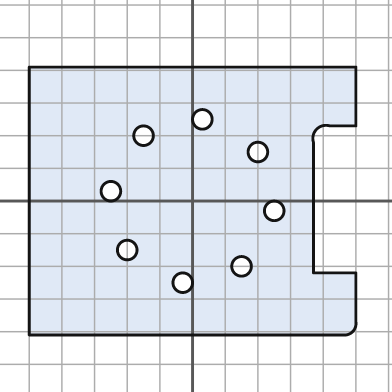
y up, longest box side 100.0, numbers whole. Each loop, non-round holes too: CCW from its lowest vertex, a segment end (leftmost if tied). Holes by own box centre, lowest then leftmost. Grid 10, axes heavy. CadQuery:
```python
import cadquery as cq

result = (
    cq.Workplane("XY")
    .moveTo(-50.0, -41.0)
    .lineTo(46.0, -41.0)
    .threePointArc((49.0, -40.0), (50.0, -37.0))
    .lineTo(50.0, -22.0)
    .lineTo(37.0, -22.0)
    .lineTo(37.0, 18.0)
    .threePointArc((38.0, 22.0), (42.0, 23.0))
    .lineTo(50.0, 23.0)
    .lineTo(50.0, 41.0)
    .lineTo(-50.0, 41.0)
    .close()
    .moveTo(-3.0, -25.0)
    .circle(3.0)
    .moveTo(15.0, -20.0)
    .circle(3.0)
    .moveTo(-20.0, -15.0)
    .circle(3.0)
    .moveTo(25.0, -3.0)
    .circle(3.0)
    .moveTo(-25.0, 3.0)
    .circle(3.0)
    .moveTo(20.0, 15.0)
    .circle(3.0)
    .moveTo(-15.0, 20.0)
    .circle(3.0)
    .moveTo(3.0, 25.0)
    .circle(3.0)
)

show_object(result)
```